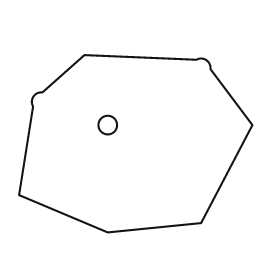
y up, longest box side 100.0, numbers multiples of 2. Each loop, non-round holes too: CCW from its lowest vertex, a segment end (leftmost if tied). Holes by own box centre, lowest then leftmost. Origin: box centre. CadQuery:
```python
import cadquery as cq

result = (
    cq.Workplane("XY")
    .moveTo(-12.0, -38.0)
    .lineTo(28.0, -34.0)
    .lineTo(50.0, 8.0)
    .lineTo(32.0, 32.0)
    .threePointArc((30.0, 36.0), (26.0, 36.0))
    .lineTo(-22.0, 38.0)
    .lineTo(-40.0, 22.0)
    .threePointArc((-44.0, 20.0), (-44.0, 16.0))
    .lineTo(-50.0, -22.0)
    .close()
    .moveTo(-12.0, 8.0)
    .circle(4.0)
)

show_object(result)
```